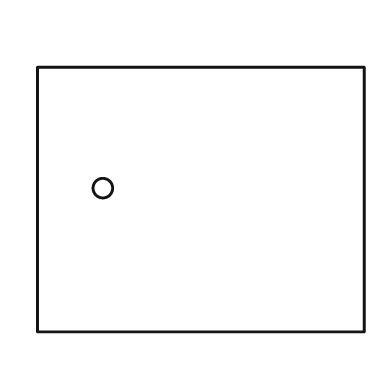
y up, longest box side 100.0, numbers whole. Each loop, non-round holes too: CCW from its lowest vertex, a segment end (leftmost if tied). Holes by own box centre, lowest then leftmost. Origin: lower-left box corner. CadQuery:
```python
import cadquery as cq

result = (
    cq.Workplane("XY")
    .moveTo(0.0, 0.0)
    .lineTo(100.0, 0.0)
    .lineTo(100.0, 81.0)
    .lineTo(0.0, 81.0)
    .close()
    .moveTo(20.0, 44.0)
    .circle(3.0)
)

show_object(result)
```